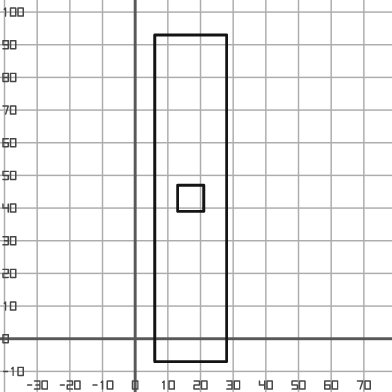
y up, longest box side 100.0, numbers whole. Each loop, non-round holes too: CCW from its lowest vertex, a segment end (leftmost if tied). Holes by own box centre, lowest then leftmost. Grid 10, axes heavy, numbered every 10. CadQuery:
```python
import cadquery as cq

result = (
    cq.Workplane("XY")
    .moveTo(6.0, -7.0)
    .lineTo(28.0, -7.0)
    .lineTo(28.0, 93.0)
    .lineTo(6.0, 93.0)
    .close()
    .moveTo(13.0, 39.0)
    .lineTo(21.0, 39.0)
    .lineTo(21.0, 47.0)
    .lineTo(13.0, 47.0)
    .close()
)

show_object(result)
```